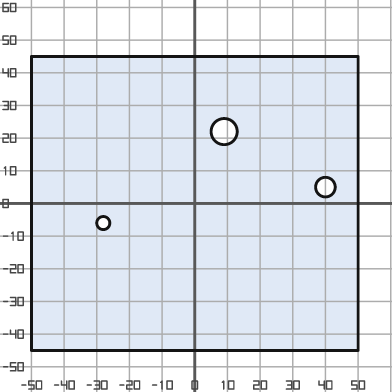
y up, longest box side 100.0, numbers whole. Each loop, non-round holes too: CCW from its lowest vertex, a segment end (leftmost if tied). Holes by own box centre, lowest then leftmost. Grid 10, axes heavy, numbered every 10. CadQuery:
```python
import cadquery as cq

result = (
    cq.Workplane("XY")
    .moveTo(-50.0, -45.0)
    .lineTo(50.0, -45.0)
    .lineTo(50.0, 45.0)
    .lineTo(-50.0, 45.0)
    .close()
    .moveTo(-28.0, -6.0)
    .circle(2.0)
    .moveTo(40.0, 5.0)
    .circle(3.0)
    .moveTo(9.0, 22.0)
    .circle(4.0)
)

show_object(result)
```